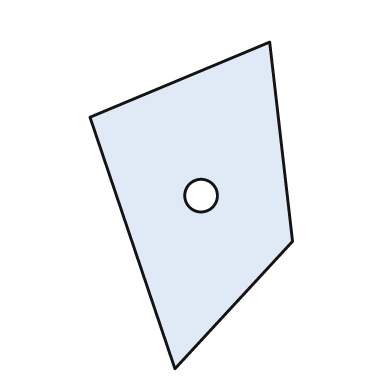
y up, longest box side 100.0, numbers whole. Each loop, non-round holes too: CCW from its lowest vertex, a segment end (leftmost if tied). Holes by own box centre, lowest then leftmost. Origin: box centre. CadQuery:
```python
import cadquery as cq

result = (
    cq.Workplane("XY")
    .moveTo(-5.0, -50.0)
    .lineTo(31.0, -11.0)
    .lineTo(24.0, 50.0)
    .lineTo(-31.0, 27.0)
    .close()
    .moveTo(3.0, 3.0)
    .circle(5.0)
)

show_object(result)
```